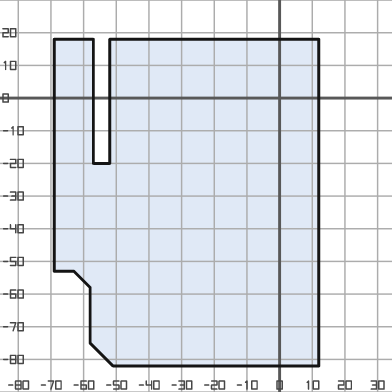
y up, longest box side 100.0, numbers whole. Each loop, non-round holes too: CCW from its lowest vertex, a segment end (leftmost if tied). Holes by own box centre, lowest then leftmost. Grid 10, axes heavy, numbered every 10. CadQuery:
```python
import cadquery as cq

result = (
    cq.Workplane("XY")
    .moveTo(-51.0, -82.0)
    .lineTo(12.0, -82.0)
    .lineTo(12.0, 18.0)
    .lineTo(-52.0, 18.0)
    .lineTo(-52.0, -20.0)
    .lineTo(-57.0, -20.0)
    .lineTo(-57.0, 18.0)
    .lineTo(-69.0, 18.0)
    .lineTo(-69.0, -53.0)
    .lineTo(-63.0, -53.0)
    .lineTo(-58.0, -58.0)
    .lineTo(-58.0, -75.0)
    .close()
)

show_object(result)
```